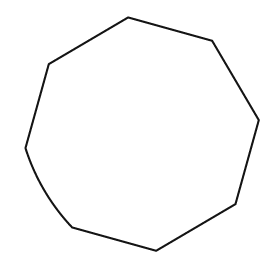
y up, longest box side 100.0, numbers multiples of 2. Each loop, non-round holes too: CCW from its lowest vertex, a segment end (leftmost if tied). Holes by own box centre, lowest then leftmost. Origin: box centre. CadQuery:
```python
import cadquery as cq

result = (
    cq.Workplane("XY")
    .moveTo(6.0, -50.0)
    .lineTo(40.0, -30.0)
    .lineTo(50.0, 6.0)
    .lineTo(30.0, 40.0)
    .lineTo(-6.0, 50.0)
    .lineTo(-40.0, 30.0)
    .lineTo(-50.0, -6.0)
    .threePointArc((-42.0, -24.0), (-30.0, -40.0))
    .close()
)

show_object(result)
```